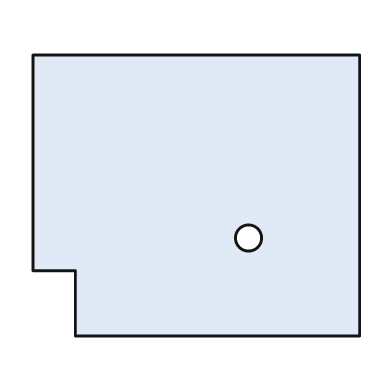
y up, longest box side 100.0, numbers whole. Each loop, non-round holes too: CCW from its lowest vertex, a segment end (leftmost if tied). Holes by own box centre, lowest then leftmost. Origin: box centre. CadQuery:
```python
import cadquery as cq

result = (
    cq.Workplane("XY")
    .moveTo(-37.0, -43.0)
    .lineTo(50.0, -43.0)
    .lineTo(50.0, 43.0)
    .lineTo(-50.0, 43.0)
    .lineTo(-50.0, -23.0)
    .lineTo(-37.0, -23.0)
    .close()
    .moveTo(16.0, -13.0)
    .circle(4.0)
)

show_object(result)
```